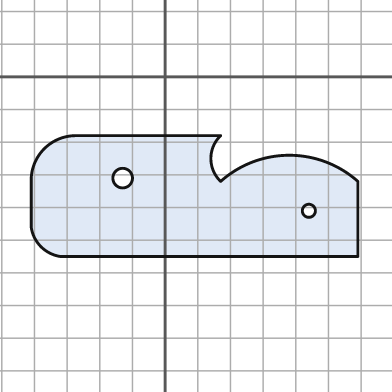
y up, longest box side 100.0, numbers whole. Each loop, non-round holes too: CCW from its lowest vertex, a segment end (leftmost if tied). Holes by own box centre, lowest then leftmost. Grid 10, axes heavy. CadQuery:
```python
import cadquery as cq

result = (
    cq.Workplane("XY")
    .moveTo(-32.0, -55.0)
    .lineTo(59.0, -55.0)
    .lineTo(59.0, -32.0)
    .threePointArc((38.0, -24.0), (17.0, -32.0))
    .threePointArc((14.0, -25.0), (17.0, -18.0))
    .lineTo(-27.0, -18.0)
    .threePointArc((-37.0, -22.0), (-41.0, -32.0))
    .lineTo(-41.0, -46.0)
    .threePointArc((-38.0, -52.0), (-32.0, -55.0))
    .close()
    .moveTo(44.0, -41.0)
    .circle(2.0)
    .moveTo(-13.0, -31.0)
    .circle(3.0)
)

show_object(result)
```